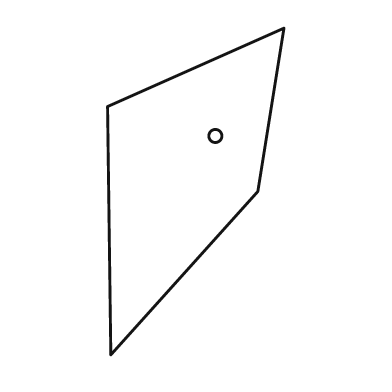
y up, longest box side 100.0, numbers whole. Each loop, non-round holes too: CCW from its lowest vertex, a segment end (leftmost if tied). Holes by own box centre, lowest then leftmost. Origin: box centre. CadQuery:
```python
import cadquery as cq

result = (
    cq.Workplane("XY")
    .moveTo(-26.0, -50.0)
    .lineTo(19.0, 0.0)
    .lineTo(27.0, 50.0)
    .lineTo(-27.0, 26.0)
    .close()
    .moveTo(6.0, 17.0)
    .circle(2.0)
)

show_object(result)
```